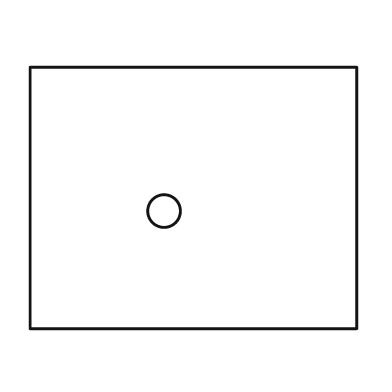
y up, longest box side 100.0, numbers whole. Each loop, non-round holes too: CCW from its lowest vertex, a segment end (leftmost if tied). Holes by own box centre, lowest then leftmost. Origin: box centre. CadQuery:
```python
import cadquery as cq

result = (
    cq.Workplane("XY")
    .moveTo(-50.0, -40.0)
    .lineTo(50.0, -40.0)
    .lineTo(50.0, 40.0)
    .lineTo(-50.0, 40.0)
    .close()
    .moveTo(-9.0, -4.0)
    .circle(5.0)
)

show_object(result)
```